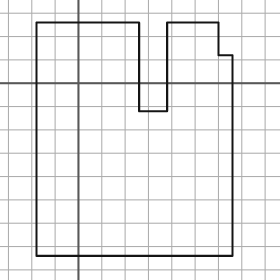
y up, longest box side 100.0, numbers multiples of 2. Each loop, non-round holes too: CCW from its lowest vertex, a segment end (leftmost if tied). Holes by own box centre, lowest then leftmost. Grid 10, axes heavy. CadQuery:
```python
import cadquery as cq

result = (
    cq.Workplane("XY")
    .moveTo(-18.0, -74.0)
    .lineTo(66.0, -74.0)
    .lineTo(66.0, 12.0)
    .lineTo(60.0, 12.0)
    .lineTo(60.0, 26.0)
    .lineTo(38.0, 26.0)
    .lineTo(38.0, -12.0)
    .lineTo(26.0, -12.0)
    .lineTo(26.0, 26.0)
    .lineTo(-18.0, 26.0)
    .close()
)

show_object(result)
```